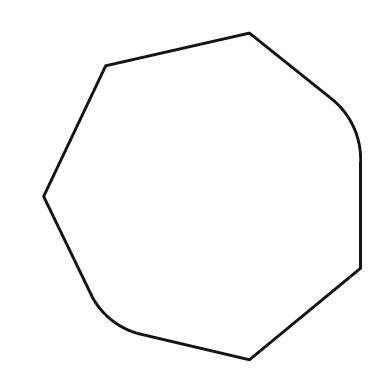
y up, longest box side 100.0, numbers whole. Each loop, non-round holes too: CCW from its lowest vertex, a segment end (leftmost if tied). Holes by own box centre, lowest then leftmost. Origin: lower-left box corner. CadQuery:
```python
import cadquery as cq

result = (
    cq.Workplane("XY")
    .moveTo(63.0, 0.0)
    .lineTo(97.0, 28.0)
    .lineTo(97.0, 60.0)
    .threePointArc((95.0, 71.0), (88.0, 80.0))
    .lineTo(63.0, 100.0)
    .lineTo(19.0, 90.0)
    .lineTo(0.0, 50.0)
    .lineTo(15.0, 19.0)
    .threePointArc((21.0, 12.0), (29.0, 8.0))
    .close()
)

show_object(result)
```